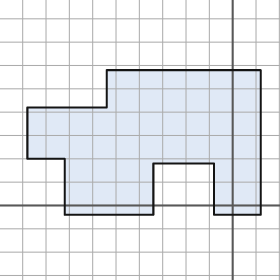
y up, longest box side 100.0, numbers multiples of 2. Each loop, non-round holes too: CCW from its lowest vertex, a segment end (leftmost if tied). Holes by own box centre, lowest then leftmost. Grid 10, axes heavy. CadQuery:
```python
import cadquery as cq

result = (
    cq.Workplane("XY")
    .moveTo(-72.0, -4.0)
    .lineTo(-34.0, -4.0)
    .lineTo(-34.0, 18.0)
    .lineTo(-8.0, 18.0)
    .lineTo(-8.0, -4.0)
    .lineTo(12.0, -4.0)
    .lineTo(12.0, 58.0)
    .lineTo(-54.0, 58.0)
    .lineTo(-54.0, 42.0)
    .lineTo(-88.0, 42.0)
    .lineTo(-88.0, 20.0)
    .lineTo(-72.0, 20.0)
    .close()
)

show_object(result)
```